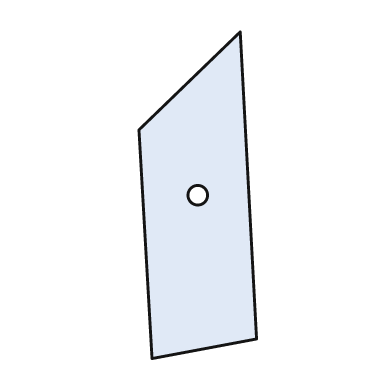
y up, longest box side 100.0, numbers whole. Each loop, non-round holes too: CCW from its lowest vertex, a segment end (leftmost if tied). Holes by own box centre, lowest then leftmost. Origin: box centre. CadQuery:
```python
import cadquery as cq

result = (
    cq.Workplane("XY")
    .moveTo(-14.0, -50.0)
    .lineTo(18.0, -44.0)
    .lineTo(13.0, 50.0)
    .lineTo(-18.0, 20.0)
    .close()
    .moveTo(0.0, 0.0)
    .circle(3.0)
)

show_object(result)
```